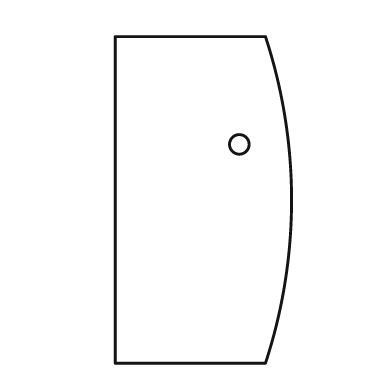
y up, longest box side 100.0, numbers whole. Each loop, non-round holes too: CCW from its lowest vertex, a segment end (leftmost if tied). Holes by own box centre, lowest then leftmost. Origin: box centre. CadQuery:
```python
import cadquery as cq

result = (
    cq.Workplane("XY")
    .moveTo(-27.0, -50.0)
    .lineTo(19.0, -50.0)
    .threePointArc((27.0, 0.0), (19.0, 50.0))
    .lineTo(-27.0, 50.0)
    .close()
    .moveTo(11.0, 17.0)
    .circle(3.0)
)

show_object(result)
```